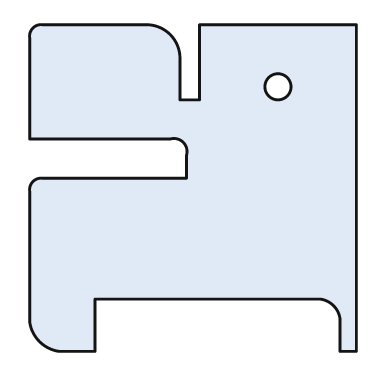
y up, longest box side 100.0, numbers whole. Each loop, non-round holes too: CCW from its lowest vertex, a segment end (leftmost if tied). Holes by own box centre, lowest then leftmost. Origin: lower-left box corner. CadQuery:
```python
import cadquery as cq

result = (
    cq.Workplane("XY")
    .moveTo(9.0, 0.0)
    .lineTo(20.0, 0.0)
    .lineTo(20.0, 16.0)
    .lineTo(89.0, 16.0)
    .threePointArc((93.0, 14.0), (95.0, 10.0))
    .lineTo(95.0, 0.0)
    .lineTo(100.0, 0.0)
    .lineTo(100.0, 100.0)
    .lineTo(52.0, 100.0)
    .lineTo(52.0, 77.0)
    .lineTo(46.0, 77.0)
    .lineTo(46.0, 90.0)
    .threePointArc((43.0, 97.0), (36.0, 100.0))
    .lineTo(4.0, 100.0)
    .threePointArc((1.0, 99.0), (0.0, 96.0))
    .lineTo(0.0, 65.0)
    .lineTo(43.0, 65.0)
    .threePointArc((47.0, 64.0), (48.0, 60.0))
    .lineTo(48.0, 53.0)
    .lineTo(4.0, 53.0)
    .threePointArc((1.0, 52.0), (0.0, 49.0))
    .lineTo(0.0, 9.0)
    .threePointArc((3.0, 3.0), (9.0, 0.0))
    .close()
    .moveTo(76.0, 81.0)
    .circle(4.0)
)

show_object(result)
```